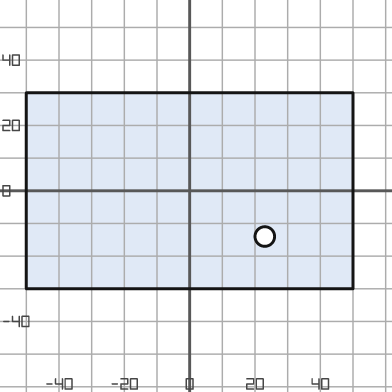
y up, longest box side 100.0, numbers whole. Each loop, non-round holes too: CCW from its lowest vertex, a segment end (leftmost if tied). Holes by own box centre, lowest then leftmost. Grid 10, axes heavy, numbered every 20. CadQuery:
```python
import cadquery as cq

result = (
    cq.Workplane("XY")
    .moveTo(-50.0, -30.0)
    .lineTo(50.0, -30.0)
    .lineTo(50.0, 30.0)
    .lineTo(-50.0, 30.0)
    .close()
    .moveTo(23.0, -14.0)
    .circle(3.0)
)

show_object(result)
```